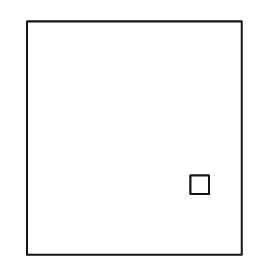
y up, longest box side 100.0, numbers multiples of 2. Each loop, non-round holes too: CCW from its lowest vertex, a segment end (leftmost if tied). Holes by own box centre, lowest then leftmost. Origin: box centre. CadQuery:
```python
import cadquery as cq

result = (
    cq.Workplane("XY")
    .moveTo(-46.0, -50.0)
    .lineTo(46.0, -50.0)
    .lineTo(46.0, 50.0)
    .lineTo(-46.0, 50.0)
    .close()
    .moveTo(24.0, -24.0)
    .lineTo(32.0, -24.0)
    .lineTo(32.0, -16.0)
    .lineTo(24.0, -16.0)
    .close()
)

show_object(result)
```